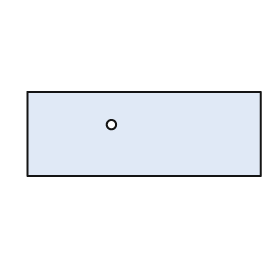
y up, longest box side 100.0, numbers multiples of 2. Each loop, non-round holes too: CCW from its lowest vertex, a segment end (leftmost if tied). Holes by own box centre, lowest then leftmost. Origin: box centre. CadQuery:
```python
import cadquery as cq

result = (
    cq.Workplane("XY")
    .moveTo(-50.0, -18.0)
    .lineTo(50.0, -18.0)
    .lineTo(50.0, 18.0)
    .lineTo(-50.0, 18.0)
    .close()
    .moveTo(-14.0, 4.0)
    .circle(2.0)
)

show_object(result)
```